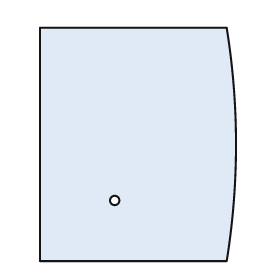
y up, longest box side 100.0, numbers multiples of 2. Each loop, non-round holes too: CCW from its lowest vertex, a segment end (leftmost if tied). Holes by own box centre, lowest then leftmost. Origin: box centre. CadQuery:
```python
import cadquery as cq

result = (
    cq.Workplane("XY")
    .moveTo(-42.0, -50.0)
    .lineTo(38.0, -50.0)
    .threePointArc((42.0, 0.0), (38.0, 50.0))
    .lineTo(-42.0, 50.0)
    .close()
    .moveTo(-10.0, -24.0)
    .circle(2.0)
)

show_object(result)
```